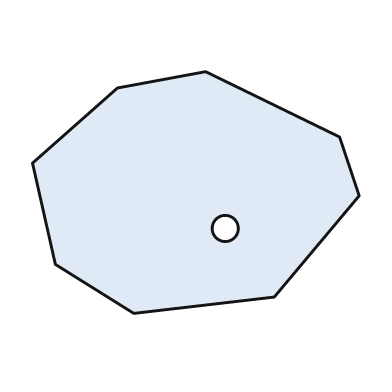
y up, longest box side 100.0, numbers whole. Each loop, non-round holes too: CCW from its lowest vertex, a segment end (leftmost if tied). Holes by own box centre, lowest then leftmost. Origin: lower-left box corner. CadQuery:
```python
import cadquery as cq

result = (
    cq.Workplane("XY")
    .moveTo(31.0, 0.0)
    .lineTo(74.0, 5.0)
    .lineTo(100.0, 36.0)
    .lineTo(94.0, 54.0)
    .lineTo(53.0, 74.0)
    .lineTo(26.0, 69.0)
    .lineTo(0.0, 46.0)
    .lineTo(7.0, 15.0)
    .close()
    .moveTo(59.0, 26.0)
    .circle(4.0)
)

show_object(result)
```